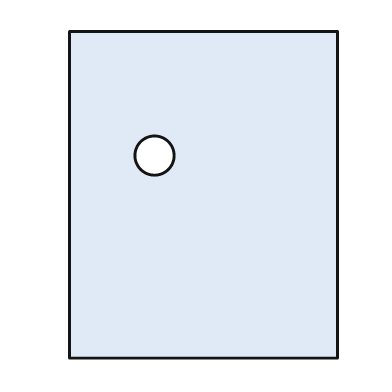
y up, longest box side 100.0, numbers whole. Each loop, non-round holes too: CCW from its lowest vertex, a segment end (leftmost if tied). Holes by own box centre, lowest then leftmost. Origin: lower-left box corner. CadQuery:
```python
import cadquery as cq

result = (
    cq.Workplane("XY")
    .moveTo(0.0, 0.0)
    .lineTo(82.0, 0.0)
    .lineTo(82.0, 100.0)
    .lineTo(0.0, 100.0)
    .close()
    .moveTo(26.0, 62.0)
    .circle(6.0)
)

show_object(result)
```